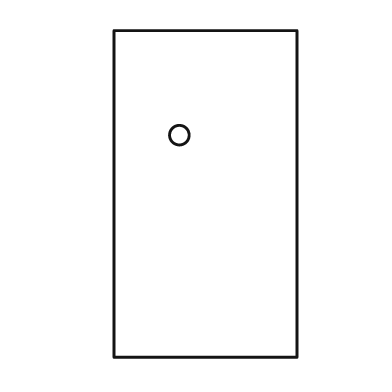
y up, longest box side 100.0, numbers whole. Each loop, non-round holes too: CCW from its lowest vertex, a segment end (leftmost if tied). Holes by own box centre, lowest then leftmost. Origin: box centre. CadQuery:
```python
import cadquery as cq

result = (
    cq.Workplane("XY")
    .moveTo(-28.0, -50.0)
    .lineTo(28.0, -50.0)
    .lineTo(28.0, 50.0)
    .lineTo(-28.0, 50.0)
    .close()
    .moveTo(-8.0, 18.0)
    .circle(3.0)
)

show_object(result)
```